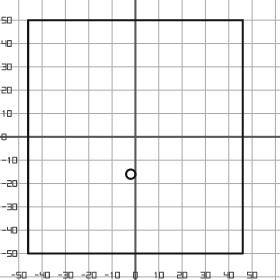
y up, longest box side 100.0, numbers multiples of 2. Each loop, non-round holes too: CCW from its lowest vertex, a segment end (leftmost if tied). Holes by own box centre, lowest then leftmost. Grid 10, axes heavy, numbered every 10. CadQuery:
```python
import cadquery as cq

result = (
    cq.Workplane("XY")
    .moveTo(-46.0, -50.0)
    .lineTo(46.0, -50.0)
    .lineTo(46.0, 50.0)
    .lineTo(-46.0, 50.0)
    .close()
    .moveTo(-2.0, -16.0)
    .circle(2.0)
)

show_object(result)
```